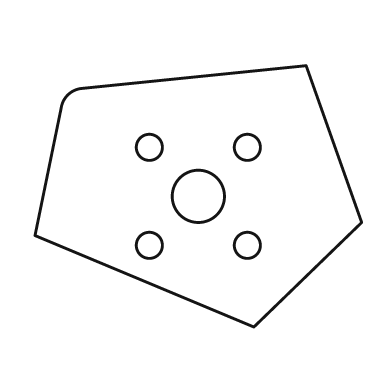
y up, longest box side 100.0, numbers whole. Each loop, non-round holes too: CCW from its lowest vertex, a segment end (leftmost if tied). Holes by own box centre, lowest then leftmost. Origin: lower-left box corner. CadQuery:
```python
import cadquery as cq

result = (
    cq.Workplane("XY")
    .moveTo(67.0, 0.0)
    .lineTo(100.0, 32.0)
    .lineTo(83.0, 80.0)
    .lineTo(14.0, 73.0)
    .threePointArc((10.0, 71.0), (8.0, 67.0))
    .lineTo(0.0, 28.0)
    .close()
    .moveTo(35.0, 25.0)
    .circle(4.0)
    .moveTo(65.0, 25.0)
    .circle(4.0)
    .moveTo(50.0, 40.0)
    .circle(8.0)
    .moveTo(35.0, 55.0)
    .circle(4.0)
    .moveTo(65.0, 55.0)
    .circle(4.0)
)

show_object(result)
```